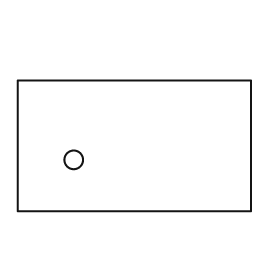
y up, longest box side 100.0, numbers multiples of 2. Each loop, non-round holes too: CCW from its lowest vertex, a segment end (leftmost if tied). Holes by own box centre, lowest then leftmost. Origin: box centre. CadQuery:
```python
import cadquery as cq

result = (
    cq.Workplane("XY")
    .moveTo(-50.0, -28.0)
    .lineTo(50.0, -28.0)
    .lineTo(50.0, 28.0)
    .lineTo(-50.0, 28.0)
    .close()
    .moveTo(-26.0, -6.0)
    .circle(4.0)
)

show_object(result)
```